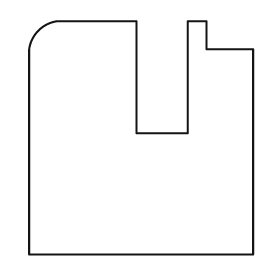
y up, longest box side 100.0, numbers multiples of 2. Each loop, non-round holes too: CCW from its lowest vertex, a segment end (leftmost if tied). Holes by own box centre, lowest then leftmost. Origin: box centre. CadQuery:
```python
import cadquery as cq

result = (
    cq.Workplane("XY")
    .moveTo(-48.0, -50.0)
    .lineTo(48.0, -50.0)
    .lineTo(48.0, 38.0)
    .lineTo(28.0, 38.0)
    .lineTo(28.0, 50.0)
    .lineTo(20.0, 50.0)
    .lineTo(20.0, 2.0)
    .lineTo(-2.0, 2.0)
    .lineTo(-2.0, 50.0)
    .lineTo(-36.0, 50.0)
    .threePointArc((-44.0, 46.0), (-48.0, 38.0))
    .close()
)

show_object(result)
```